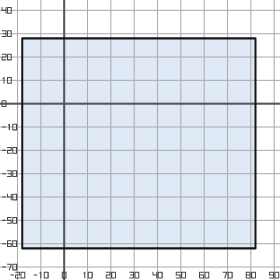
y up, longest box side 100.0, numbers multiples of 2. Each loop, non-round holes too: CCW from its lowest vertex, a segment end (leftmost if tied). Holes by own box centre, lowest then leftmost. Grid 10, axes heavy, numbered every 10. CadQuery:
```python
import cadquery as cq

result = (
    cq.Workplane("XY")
    .moveTo(-18.0, -62.0)
    .lineTo(82.0, -62.0)
    .lineTo(82.0, 28.0)
    .lineTo(-18.0, 28.0)
    .close()
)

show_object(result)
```